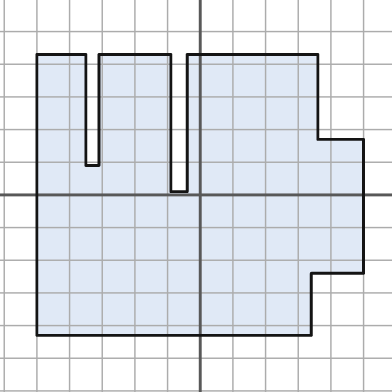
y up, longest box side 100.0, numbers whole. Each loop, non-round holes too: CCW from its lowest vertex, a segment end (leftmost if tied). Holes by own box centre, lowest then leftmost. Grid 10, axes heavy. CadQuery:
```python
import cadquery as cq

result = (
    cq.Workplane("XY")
    .moveTo(-50.0, -43.0)
    .lineTo(34.0, -43.0)
    .lineTo(34.0, -24.0)
    .lineTo(50.0, -24.0)
    .lineTo(50.0, 17.0)
    .lineTo(36.0, 17.0)
    .lineTo(36.0, 43.0)
    .lineTo(-4.0, 43.0)
    .lineTo(-4.0, 1.0)
    .lineTo(-9.0, 1.0)
    .lineTo(-9.0, 43.0)
    .lineTo(-31.0, 43.0)
    .lineTo(-31.0, 9.0)
    .lineTo(-35.0, 9.0)
    .lineTo(-35.0, 43.0)
    .lineTo(-50.0, 43.0)
    .close()
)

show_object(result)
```